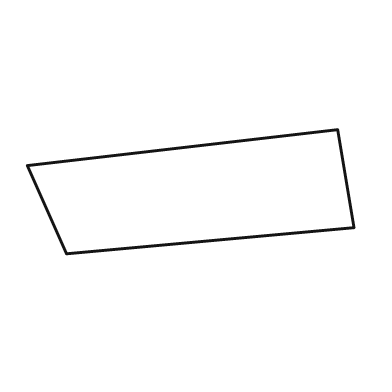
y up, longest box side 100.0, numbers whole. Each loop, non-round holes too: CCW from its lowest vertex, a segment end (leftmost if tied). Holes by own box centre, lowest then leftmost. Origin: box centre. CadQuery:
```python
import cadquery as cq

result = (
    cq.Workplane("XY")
    .moveTo(-38.0, -19.0)
    .lineTo(50.0, -11.0)
    .lineTo(45.0, 19.0)
    .lineTo(-50.0, 8.0)
    .close()
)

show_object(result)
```